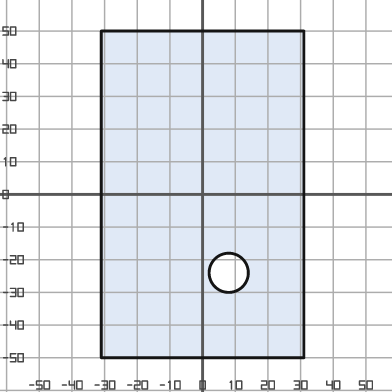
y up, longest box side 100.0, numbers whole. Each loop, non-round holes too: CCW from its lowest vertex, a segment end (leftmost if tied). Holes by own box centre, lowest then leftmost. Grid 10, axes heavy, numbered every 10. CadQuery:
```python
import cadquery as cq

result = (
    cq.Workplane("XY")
    .moveTo(-31.0, -50.0)
    .lineTo(31.0, -50.0)
    .lineTo(31.0, 50.0)
    .lineTo(-31.0, 50.0)
    .close()
    .moveTo(8.0, -24.0)
    .circle(6.0)
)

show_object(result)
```